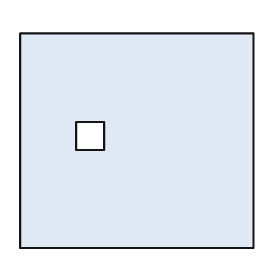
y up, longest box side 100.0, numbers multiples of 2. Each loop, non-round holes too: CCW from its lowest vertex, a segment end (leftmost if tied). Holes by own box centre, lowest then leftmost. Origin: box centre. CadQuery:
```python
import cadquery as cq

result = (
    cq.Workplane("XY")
    .moveTo(-50.0, -46.0)
    .lineTo(50.0, -46.0)
    .lineTo(50.0, 46.0)
    .lineTo(-50.0, 46.0)
    .close()
    .moveTo(-26.0, -4.0)
    .lineTo(-14.0, -4.0)
    .lineTo(-14.0, 8.0)
    .lineTo(-26.0, 8.0)
    .close()
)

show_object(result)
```